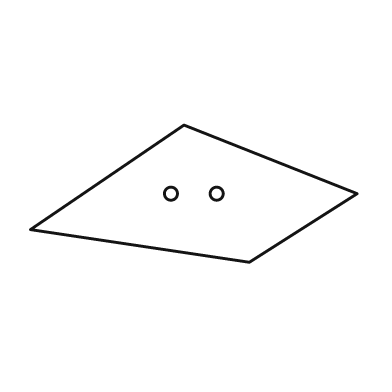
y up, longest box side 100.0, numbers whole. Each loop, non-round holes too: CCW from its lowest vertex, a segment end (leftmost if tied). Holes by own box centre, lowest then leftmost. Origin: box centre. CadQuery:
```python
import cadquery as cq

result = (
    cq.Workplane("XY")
    .moveTo(17.0, -21.0)
    .lineTo(50.0, 0.0)
    .lineTo(-3.0, 21.0)
    .lineTo(-50.0, -11.0)
    .close()
    .moveTo(-7.0, 0.0)
    .circle(2.0)
    .moveTo(7.0, 0.0)
    .circle(2.0)
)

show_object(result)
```